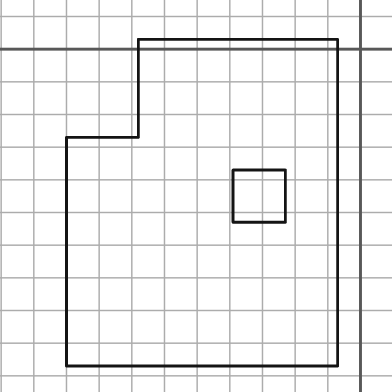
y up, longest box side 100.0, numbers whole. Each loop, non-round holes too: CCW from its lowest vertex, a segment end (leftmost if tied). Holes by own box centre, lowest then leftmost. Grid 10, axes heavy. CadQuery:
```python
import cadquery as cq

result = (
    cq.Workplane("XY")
    .moveTo(-90.0, -97.0)
    .lineTo(-7.0, -97.0)
    .lineTo(-7.0, 3.0)
    .lineTo(-68.0, 3.0)
    .lineTo(-68.0, -27.0)
    .lineTo(-90.0, -27.0)
    .close()
    .moveTo(-39.0, -53.0)
    .lineTo(-23.0, -53.0)
    .lineTo(-23.0, -37.0)
    .lineTo(-39.0, -37.0)
    .close()
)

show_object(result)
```